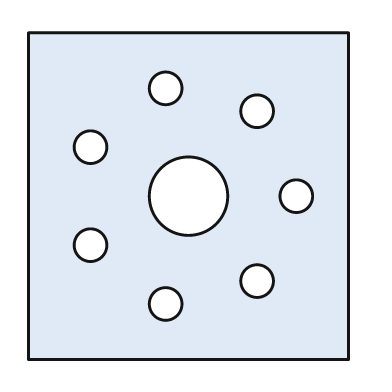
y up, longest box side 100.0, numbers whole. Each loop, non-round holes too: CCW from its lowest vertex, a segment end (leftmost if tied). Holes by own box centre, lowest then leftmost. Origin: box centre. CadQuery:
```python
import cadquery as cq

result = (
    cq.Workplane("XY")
    .moveTo(-49.0, -50.0)
    .lineTo(49.0, -50.0)
    .lineTo(49.0, 50.0)
    .lineTo(-49.0, 50.0)
    .close()
    .moveTo(-7.0, -33.0)
    .circle(5.0)
    .moveTo(21.0, -26.0)
    .circle(5.0)
    .moveTo(-30.0, -15.0)
    .circle(5.0)
    .moveTo(0.0, 0.0)
    .circle(12.0)
    .moveTo(33.0, 0.0)
    .circle(5.0)
    .moveTo(-30.0, 15.0)
    .circle(5.0)
    .moveTo(21.0, 26.0)
    .circle(5.0)
    .moveTo(-7.0, 33.0)
    .circle(5.0)
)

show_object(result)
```